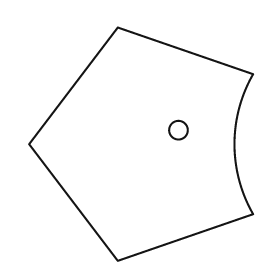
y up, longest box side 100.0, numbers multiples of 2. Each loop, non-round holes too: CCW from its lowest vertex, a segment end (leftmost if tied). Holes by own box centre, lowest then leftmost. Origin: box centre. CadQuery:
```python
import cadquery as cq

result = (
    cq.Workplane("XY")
    .moveTo(-10.0, -50.0)
    .lineTo(48.0, -30.0)
    .threePointArc((40.0, 0.0), (48.0, 30.0))
    .lineTo(-10.0, 50.0)
    .lineTo(-48.0, 0.0)
    .close()
    .moveTo(16.0, 6.0)
    .circle(4.0)
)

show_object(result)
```